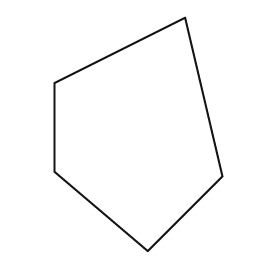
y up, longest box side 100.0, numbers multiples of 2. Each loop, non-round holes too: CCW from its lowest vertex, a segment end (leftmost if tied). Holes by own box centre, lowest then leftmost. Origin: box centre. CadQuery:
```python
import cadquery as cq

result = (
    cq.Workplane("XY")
    .moveTo(4.0, -50.0)
    .lineTo(36.0, -18.0)
    .lineTo(20.0, 50.0)
    .lineTo(-36.0, 22.0)
    .lineTo(-36.0, -16.0)
    .close()
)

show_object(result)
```